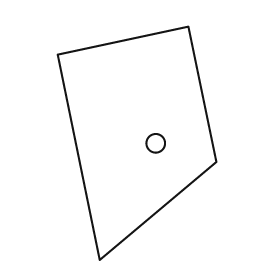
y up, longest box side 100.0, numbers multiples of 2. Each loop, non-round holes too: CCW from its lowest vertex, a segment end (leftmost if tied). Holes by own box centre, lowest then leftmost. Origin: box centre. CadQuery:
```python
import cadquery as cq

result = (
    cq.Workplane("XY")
    .moveTo(-16.0, -50.0)
    .lineTo(34.0, -8.0)
    .lineTo(22.0, 50.0)
    .lineTo(-34.0, 38.0)
    .close()
    .moveTo(8.0, 0.0)
    .circle(4.0)
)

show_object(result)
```